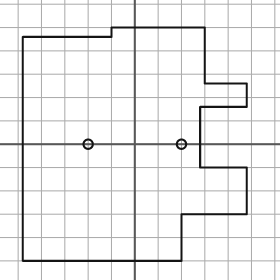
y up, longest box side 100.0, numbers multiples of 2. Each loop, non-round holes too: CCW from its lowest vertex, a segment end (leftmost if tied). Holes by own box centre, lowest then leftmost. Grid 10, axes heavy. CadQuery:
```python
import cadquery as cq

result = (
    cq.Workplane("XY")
    .moveTo(-48.0, -50.0)
    .lineTo(20.0, -50.0)
    .lineTo(20.0, -30.0)
    .lineTo(48.0, -30.0)
    .lineTo(48.0, -10.0)
    .lineTo(28.0, -10.0)
    .lineTo(28.0, 16.0)
    .lineTo(48.0, 16.0)
    .lineTo(48.0, 26.0)
    .lineTo(30.0, 26.0)
    .lineTo(30.0, 50.0)
    .lineTo(-10.0, 50.0)
    .lineTo(-10.0, 46.0)
    .lineTo(-48.0, 46.0)
    .close()
    .moveTo(-20.0, 0.0)
    .circle(2.0)
    .moveTo(20.0, 0.0)
    .circle(2.0)
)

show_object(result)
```